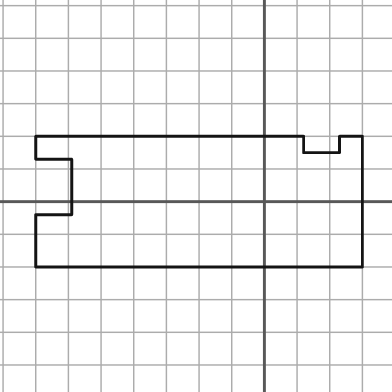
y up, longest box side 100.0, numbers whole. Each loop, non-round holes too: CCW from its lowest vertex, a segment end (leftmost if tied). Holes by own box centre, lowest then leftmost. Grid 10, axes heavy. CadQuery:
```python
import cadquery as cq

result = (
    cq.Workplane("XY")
    .moveTo(-70.0, -20.0)
    .lineTo(30.0, -20.0)
    .lineTo(30.0, 20.0)
    .lineTo(23.0, 20.0)
    .lineTo(23.0, 15.0)
    .lineTo(12.0, 15.0)
    .lineTo(12.0, 20.0)
    .lineTo(-70.0, 20.0)
    .lineTo(-70.0, 13.0)
    .lineTo(-59.0, 13.0)
    .lineTo(-59.0, -4.0)
    .lineTo(-70.0, -4.0)
    .close()
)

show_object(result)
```